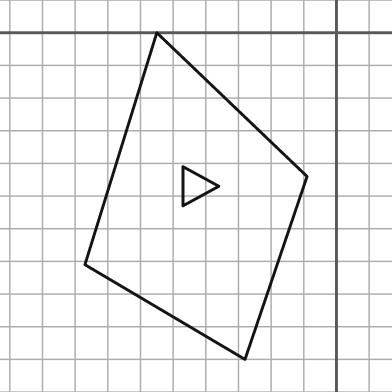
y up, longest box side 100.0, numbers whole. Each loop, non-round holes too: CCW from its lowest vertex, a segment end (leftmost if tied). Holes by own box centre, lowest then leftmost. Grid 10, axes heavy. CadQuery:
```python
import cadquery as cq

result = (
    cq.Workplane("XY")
    .moveTo(-28.0, -100.0)
    .lineTo(-9.0, -44.0)
    .lineTo(-55.0, 0.0)
    .lineTo(-77.0, -71.0)
    .close()
    .moveTo(-47.0, -53.0)
    .lineTo(-36.0, -47.0)
    .lineTo(-47.0, -41.0)
    .close()
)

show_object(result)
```